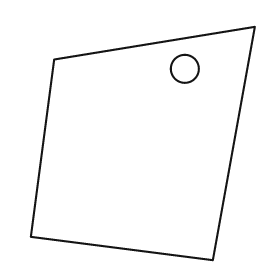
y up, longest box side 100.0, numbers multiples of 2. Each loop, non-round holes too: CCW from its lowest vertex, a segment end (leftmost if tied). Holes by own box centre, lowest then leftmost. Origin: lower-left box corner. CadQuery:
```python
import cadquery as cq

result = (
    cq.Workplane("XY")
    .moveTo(78.0, 0.0)
    .lineTo(96.0, 100.0)
    .lineTo(10.0, 86.0)
    .lineTo(0.0, 10.0)
    .close()
    .moveTo(66.0, 82.0)
    .circle(6.0)
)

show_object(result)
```